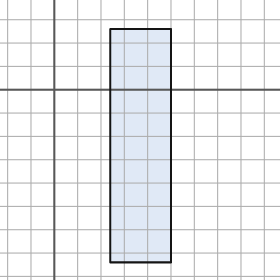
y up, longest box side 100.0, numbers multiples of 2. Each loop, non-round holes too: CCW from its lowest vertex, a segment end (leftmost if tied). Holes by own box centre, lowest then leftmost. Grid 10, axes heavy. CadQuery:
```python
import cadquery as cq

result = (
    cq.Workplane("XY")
    .moveTo(24.0, -74.0)
    .lineTo(50.0, -74.0)
    .lineTo(50.0, 26.0)
    .lineTo(24.0, 26.0)
    .close()
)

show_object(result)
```